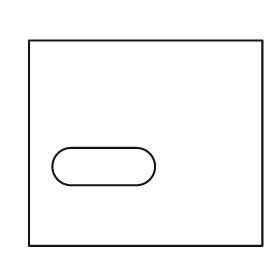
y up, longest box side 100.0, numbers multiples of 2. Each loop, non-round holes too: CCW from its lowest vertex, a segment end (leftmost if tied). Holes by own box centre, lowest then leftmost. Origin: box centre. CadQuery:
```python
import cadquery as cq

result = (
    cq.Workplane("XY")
    .moveTo(-50.0, -44.0)
    .lineTo(50.0, -44.0)
    .lineTo(50.0, 44.0)
    .lineTo(-50.0, 44.0)
    .close()
    .moveTo(-32.0, -18.0)
    .lineTo(-4.0, -18.0)
    .threePointArc((4.0, -10.0), (-4.0, -2.0))
    .lineTo(-32.0, -2.0)
    .threePointArc((-40.0, -10.0), (-32.0, -18.0))
    .close()
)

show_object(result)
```